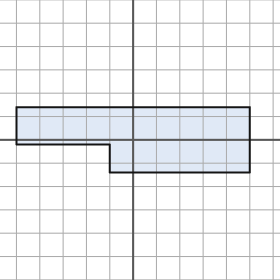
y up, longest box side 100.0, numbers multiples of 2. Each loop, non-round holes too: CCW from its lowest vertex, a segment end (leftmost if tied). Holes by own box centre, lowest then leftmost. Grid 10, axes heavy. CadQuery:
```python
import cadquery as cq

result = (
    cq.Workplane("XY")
    .moveTo(-10.0, -14.0)
    .lineTo(50.0, -14.0)
    .lineTo(50.0, 14.0)
    .lineTo(-50.0, 14.0)
    .lineTo(-50.0, -2.0)
    .lineTo(-10.0, -2.0)
    .close()
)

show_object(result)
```